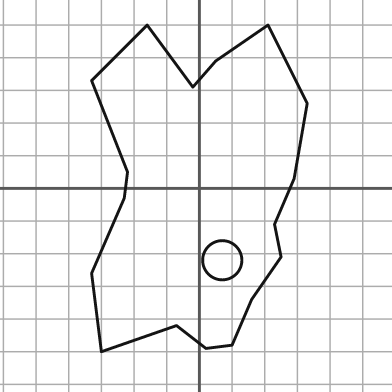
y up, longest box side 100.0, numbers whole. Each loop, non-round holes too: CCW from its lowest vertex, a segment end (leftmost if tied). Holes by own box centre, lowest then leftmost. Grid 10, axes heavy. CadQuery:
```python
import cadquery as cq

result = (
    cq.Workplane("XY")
    .moveTo(-30.0, -50.0)
    .lineTo(-7.0, -42.0)
    .lineTo(2.0, -49.0)
    .lineTo(10.0, -48.0)
    .lineTo(16.0, -34.0)
    .lineTo(25.0, -21.0)
    .lineTo(23.0, -11.0)
    .lineTo(29.0, 3.0)
    .lineTo(33.0, 26.0)
    .lineTo(21.0, 50.0)
    .lineTo(5.0, 39.0)
    .lineTo(-2.0, 31.0)
    .lineTo(-16.0, 50.0)
    .lineTo(-33.0, 33.0)
    .lineTo(-22.0, 5.0)
    .lineTo(-23.0, -3.0)
    .lineTo(-33.0, -26.0)
    .close()
    .moveTo(7.0, -22.0)
    .circle(6.0)
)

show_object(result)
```